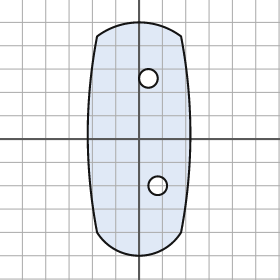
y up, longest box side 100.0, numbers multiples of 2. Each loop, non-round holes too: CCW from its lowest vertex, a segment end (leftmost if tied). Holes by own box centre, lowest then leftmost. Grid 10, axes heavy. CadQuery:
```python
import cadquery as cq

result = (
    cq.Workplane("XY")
    .moveTo(-18.0, -40.0)
    .threePointArc((0.0, -50.0), (18.0, -40.0))
    .threePointArc((22.0, 2.0), (18.0, 44.0))
    .threePointArc((0.0, 50.0), (-18.0, 44.0))
    .threePointArc((-22.0, 2.0), (-18.0, -40.0))
    .close()
    .moveTo(8.0, -20.0)
    .circle(4.0)
    .moveTo(4.0, 26.0)
    .circle(4.0)
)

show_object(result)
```